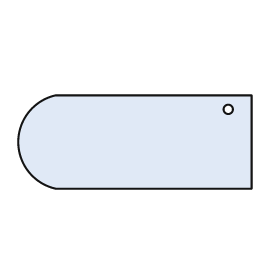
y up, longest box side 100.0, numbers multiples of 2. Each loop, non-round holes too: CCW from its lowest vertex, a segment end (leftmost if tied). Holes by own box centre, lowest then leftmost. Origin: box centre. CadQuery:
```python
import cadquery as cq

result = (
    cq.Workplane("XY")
    .moveTo(-34.0, -20.0)
    .lineTo(50.0, -20.0)
    .lineTo(50.0, 20.0)
    .lineTo(-34.0, 20.0)
    .threePointArc((-50.0, 0.0), (-34.0, -20.0))
    .close()
    .moveTo(40.0, 14.0)
    .circle(2.0)
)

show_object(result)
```